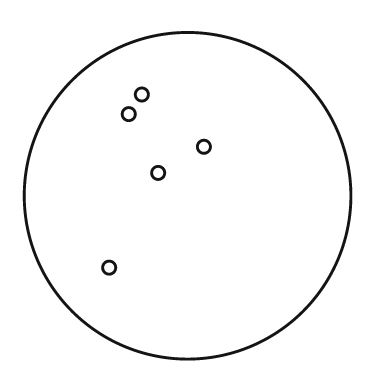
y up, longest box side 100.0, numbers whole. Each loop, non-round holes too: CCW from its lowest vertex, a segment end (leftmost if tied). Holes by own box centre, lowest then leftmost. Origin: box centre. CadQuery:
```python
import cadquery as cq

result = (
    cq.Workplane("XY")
    .moveTo(0.0, 0.0)
    .circle(50.0)
    .moveTo(-24.0, -22.0)
    .circle(2.0)
    .moveTo(-9.0, 7.0)
    .circle(2.0)
    .moveTo(5.0, 15.0)
    .circle(2.0)
    .moveTo(-18.0, 25.0)
    .circle(2.0)
    .moveTo(-14.0, 31.0)
    .circle(2.0)
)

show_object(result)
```